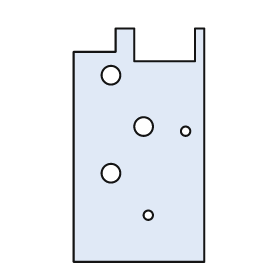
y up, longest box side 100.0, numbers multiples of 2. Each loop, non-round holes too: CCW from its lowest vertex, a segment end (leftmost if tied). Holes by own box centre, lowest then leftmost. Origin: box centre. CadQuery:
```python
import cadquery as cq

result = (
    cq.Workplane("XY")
    .moveTo(-28.0, -50.0)
    .lineTo(28.0, -50.0)
    .lineTo(28.0, 50.0)
    .lineTo(24.0, 50.0)
    .lineTo(24.0, 36.0)
    .lineTo(-2.0, 36.0)
    .lineTo(-2.0, 50.0)
    .lineTo(-10.0, 50.0)
    .lineTo(-10.0, 40.0)
    .lineTo(-28.0, 40.0)
    .close()
    .moveTo(4.0, -30.0)
    .circle(2.0)
    .moveTo(-12.0, -12.0)
    .circle(4.0)
    .moveTo(20.0, 6.0)
    .circle(2.0)
    .moveTo(2.0, 8.0)
    .circle(4.0)
    .moveTo(-12.0, 30.0)
    .circle(4.0)
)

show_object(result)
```